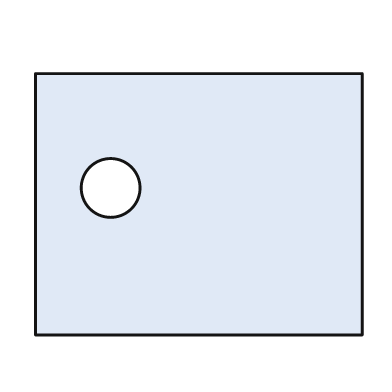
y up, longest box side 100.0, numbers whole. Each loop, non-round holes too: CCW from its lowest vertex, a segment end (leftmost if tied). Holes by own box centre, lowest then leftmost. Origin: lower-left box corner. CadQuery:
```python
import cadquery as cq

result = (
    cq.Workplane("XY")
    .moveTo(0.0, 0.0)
    .lineTo(100.0, 0.0)
    .lineTo(100.0, 80.0)
    .lineTo(0.0, 80.0)
    .close()
    .moveTo(23.0, 45.0)
    .circle(9.0)
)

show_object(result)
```